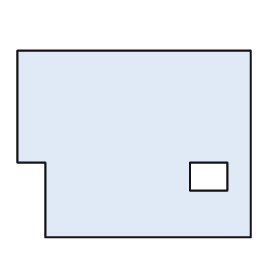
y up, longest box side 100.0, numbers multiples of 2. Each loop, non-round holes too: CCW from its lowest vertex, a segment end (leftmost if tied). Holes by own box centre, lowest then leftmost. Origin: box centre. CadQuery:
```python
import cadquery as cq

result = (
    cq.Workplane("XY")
    .moveTo(-38.0, -40.0)
    .lineTo(50.0, -40.0)
    .lineTo(50.0, 40.0)
    .lineTo(-50.0, 40.0)
    .lineTo(-50.0, -8.0)
    .lineTo(-38.0, -8.0)
    .close()
    .moveTo(24.0, -20.0)
    .lineTo(40.0, -20.0)
    .lineTo(40.0, -8.0)
    .lineTo(24.0, -8.0)
    .close()
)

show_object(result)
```